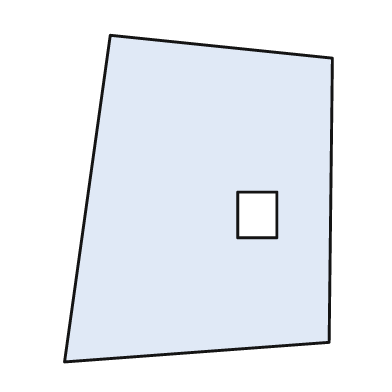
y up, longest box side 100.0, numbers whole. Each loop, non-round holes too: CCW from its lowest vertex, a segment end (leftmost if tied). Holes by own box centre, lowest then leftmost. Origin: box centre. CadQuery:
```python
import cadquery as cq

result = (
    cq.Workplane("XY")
    .moveTo(-41.0, -50.0)
    .lineTo(40.0, -44.0)
    .lineTo(41.0, 43.0)
    .lineTo(-27.0, 50.0)
    .close()
    .moveTo(12.0, -12.0)
    .lineTo(24.0, -12.0)
    .lineTo(24.0, 2.0)
    .lineTo(12.0, 2.0)
    .close()
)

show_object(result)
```